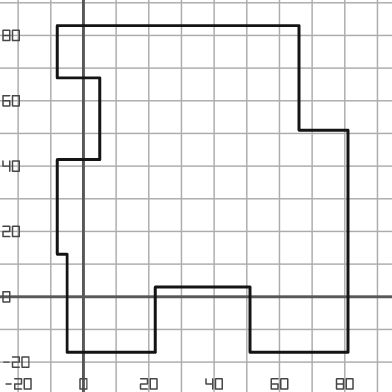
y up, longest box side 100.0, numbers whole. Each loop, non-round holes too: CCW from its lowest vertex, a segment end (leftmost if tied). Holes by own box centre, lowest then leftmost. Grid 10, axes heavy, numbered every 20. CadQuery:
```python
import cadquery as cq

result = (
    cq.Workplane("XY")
    .moveTo(-5.0, -17.0)
    .lineTo(22.0, -17.0)
    .lineTo(22.0, 3.0)
    .lineTo(51.0, 3.0)
    .lineTo(51.0, -17.0)
    .lineTo(81.0, -17.0)
    .lineTo(81.0, 51.0)
    .lineTo(66.0, 51.0)
    .lineTo(66.0, 83.0)
    .lineTo(-8.0, 83.0)
    .lineTo(-8.0, 67.0)
    .lineTo(5.0, 67.0)
    .lineTo(5.0, 42.0)
    .lineTo(-8.0, 42.0)
    .lineTo(-8.0, 13.0)
    .lineTo(-5.0, 13.0)
    .close()
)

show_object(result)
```